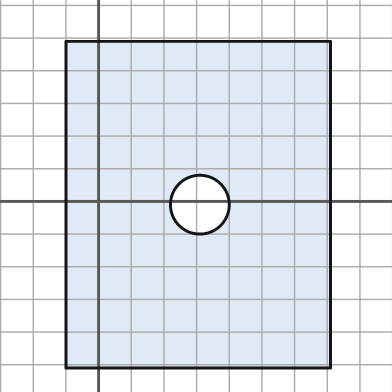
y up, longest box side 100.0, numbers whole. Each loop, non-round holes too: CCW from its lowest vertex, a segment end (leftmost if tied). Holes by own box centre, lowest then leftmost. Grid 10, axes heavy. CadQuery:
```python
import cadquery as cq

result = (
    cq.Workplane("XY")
    .moveTo(-10.0, -51.0)
    .lineTo(71.0, -51.0)
    .lineTo(71.0, 49.0)
    .lineTo(-10.0, 49.0)
    .close()
    .moveTo(31.0, -1.0)
    .circle(9.0)
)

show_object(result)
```